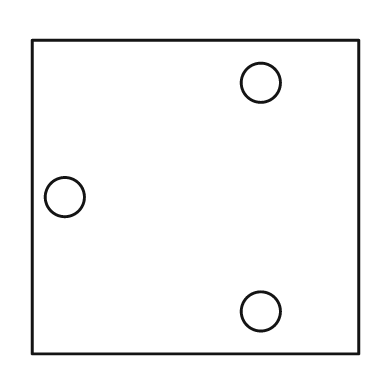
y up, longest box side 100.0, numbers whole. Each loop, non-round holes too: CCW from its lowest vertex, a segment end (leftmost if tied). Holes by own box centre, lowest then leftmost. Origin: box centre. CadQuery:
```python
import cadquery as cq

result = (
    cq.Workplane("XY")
    .moveTo(-50.0, -48.0)
    .lineTo(50.0, -48.0)
    .lineTo(50.0, 48.0)
    .lineTo(-50.0, 48.0)
    .close()
    .moveTo(20.0, -35.0)
    .circle(6.0)
    .moveTo(-40.0, 0.0)
    .circle(6.0)
    .moveTo(20.0, 35.0)
    .circle(6.0)
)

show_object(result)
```